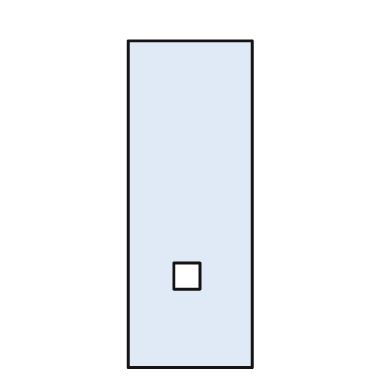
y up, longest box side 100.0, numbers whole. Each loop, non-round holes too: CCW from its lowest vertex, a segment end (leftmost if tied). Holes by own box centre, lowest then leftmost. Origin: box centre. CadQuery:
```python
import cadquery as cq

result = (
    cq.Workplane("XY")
    .moveTo(-19.0, -50.0)
    .lineTo(19.0, -50.0)
    .lineTo(19.0, 50.0)
    .lineTo(-19.0, 50.0)
    .close()
    .moveTo(-5.0, -26.0)
    .lineTo(3.0, -26.0)
    .lineTo(3.0, -18.0)
    .lineTo(-5.0, -18.0)
    .close()
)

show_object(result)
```